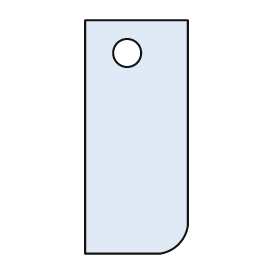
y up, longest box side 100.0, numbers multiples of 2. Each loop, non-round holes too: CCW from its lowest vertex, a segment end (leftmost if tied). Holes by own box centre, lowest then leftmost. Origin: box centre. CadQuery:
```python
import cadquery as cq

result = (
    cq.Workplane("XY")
    .moveTo(-22.0, -50.0)
    .lineTo(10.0, -50.0)
    .threePointArc((18.0, -46.0), (22.0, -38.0))
    .lineTo(22.0, 50.0)
    .lineTo(-22.0, 50.0)
    .close()
    .moveTo(-4.0, 36.0)
    .circle(6.0)
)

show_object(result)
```